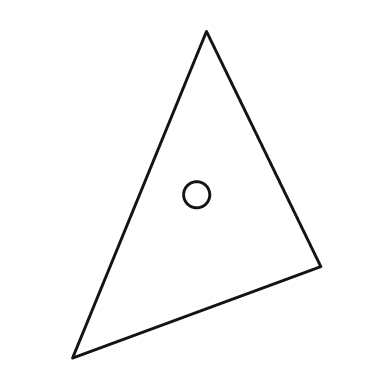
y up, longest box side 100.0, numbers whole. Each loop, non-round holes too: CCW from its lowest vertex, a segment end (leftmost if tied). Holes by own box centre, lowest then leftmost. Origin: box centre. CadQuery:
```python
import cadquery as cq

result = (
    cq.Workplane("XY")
    .moveTo(-38.0, -50.0)
    .lineTo(38.0, -22.0)
    .lineTo(3.0, 50.0)
    .close()
    .moveTo(0.0, 0.0)
    .circle(4.0)
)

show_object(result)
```